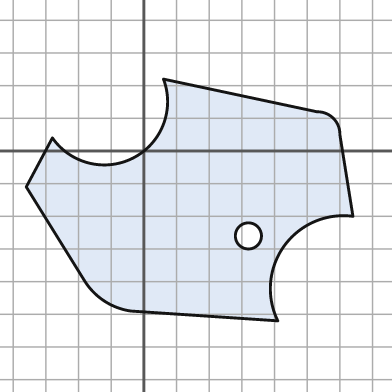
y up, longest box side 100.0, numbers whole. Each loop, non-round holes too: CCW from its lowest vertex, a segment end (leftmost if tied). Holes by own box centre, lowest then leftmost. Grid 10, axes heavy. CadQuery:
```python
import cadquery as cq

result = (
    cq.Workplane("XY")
    .moveTo(41.0, -52.0)
    .threePointArc((43.0, -29.0), (64.0, -20.0))
    .lineTo(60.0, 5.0)
    .threePointArc((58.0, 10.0), (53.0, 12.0))
    .lineTo(6.0, 22.0)
    .threePointArc((-3.0, -2.0), (-28.0, 4.0))
    .lineTo(-36.0, -11.0)
    .lineTo(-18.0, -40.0)
    .threePointArc((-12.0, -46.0), (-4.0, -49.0))
    .close()
    .moveTo(32.0, -26.0)
    .circle(4.0)
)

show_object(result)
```